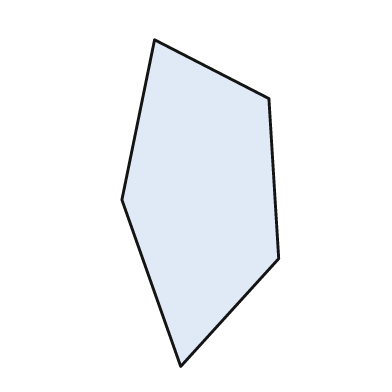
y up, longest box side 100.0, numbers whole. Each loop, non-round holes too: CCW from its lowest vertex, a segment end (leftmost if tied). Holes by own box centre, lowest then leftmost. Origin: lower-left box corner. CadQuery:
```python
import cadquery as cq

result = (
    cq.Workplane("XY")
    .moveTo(18.0, 0.0)
    .lineTo(48.0, 33.0)
    .lineTo(45.0, 82.0)
    .lineTo(10.0, 100.0)
    .lineTo(0.0, 51.0)
    .close()
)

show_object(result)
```